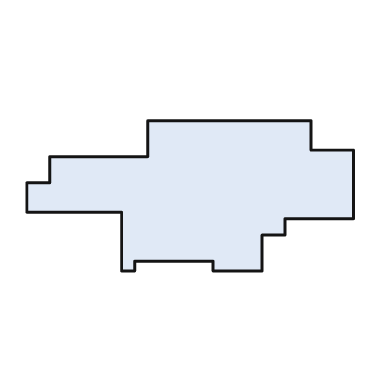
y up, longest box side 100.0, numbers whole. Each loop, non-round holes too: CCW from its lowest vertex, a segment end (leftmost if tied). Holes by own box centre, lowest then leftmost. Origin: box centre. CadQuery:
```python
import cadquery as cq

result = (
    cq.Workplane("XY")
    .moveTo(-21.0, -23.0)
    .lineTo(-17.0, -23.0)
    .lineTo(-17.0, -20.0)
    .lineTo(7.0, -20.0)
    .lineTo(7.0, -23.0)
    .lineTo(22.0, -23.0)
    .lineTo(22.0, -12.0)
    .lineTo(29.0, -12.0)
    .lineTo(29.0, -7.0)
    .lineTo(50.0, -7.0)
    .lineTo(50.0, 14.0)
    .lineTo(37.0, 14.0)
    .lineTo(37.0, 23.0)
    .lineTo(-13.0, 23.0)
    .lineTo(-13.0, 12.0)
    .lineTo(-43.0, 12.0)
    .lineTo(-43.0, 4.0)
    .lineTo(-50.0, 4.0)
    .lineTo(-50.0, -5.0)
    .lineTo(-21.0, -5.0)
    .close()
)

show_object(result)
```